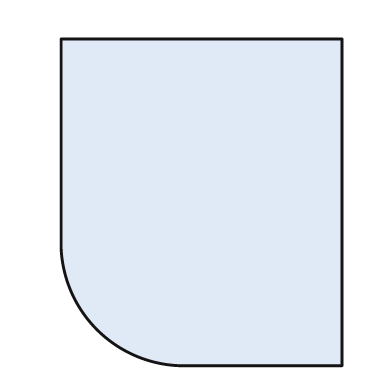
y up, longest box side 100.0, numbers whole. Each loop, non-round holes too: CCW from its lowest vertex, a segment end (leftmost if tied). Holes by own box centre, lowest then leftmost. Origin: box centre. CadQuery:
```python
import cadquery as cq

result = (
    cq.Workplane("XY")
    .moveTo(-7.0, -50.0)
    .lineTo(43.0, -50.0)
    .lineTo(43.0, 50.0)
    .lineTo(-43.0, 50.0)
    .lineTo(-43.0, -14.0)
    .threePointArc((-32.0, -39.0), (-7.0, -50.0))
    .close()
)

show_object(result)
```